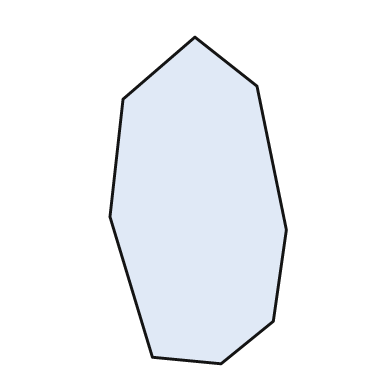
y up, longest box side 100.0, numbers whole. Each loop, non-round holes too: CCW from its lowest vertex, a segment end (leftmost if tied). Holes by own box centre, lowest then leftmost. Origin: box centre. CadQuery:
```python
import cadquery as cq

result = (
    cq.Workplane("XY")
    .moveTo(7.0, -50.0)
    .lineTo(23.0, -37.0)
    .lineTo(27.0, -9.0)
    .lineTo(18.0, 35.0)
    .lineTo(-1.0, 50.0)
    .lineTo(-23.0, 31.0)
    .lineTo(-27.0, -5.0)
    .lineTo(-14.0, -48.0)
    .close()
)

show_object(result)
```